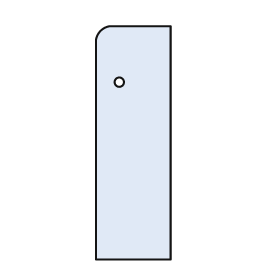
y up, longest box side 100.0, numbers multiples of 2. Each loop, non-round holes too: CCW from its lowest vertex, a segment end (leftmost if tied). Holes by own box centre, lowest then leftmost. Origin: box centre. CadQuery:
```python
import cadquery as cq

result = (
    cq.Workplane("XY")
    .moveTo(-16.0, -50.0)
    .lineTo(16.0, -50.0)
    .lineTo(16.0, 50.0)
    .lineTo(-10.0, 50.0)
    .threePointArc((-14.0, 48.0), (-16.0, 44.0))
    .close()
    .moveTo(-6.0, 26.0)
    .circle(2.0)
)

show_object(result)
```